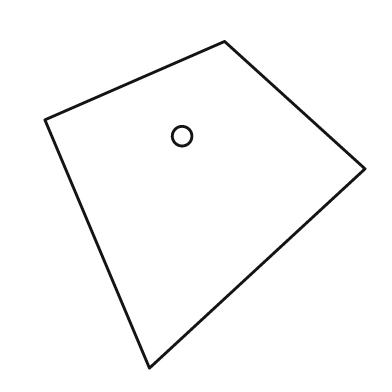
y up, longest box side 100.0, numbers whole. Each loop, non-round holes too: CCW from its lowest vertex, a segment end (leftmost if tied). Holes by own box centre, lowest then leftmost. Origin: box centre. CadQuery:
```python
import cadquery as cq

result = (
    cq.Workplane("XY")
    .moveTo(-17.0, -50.0)
    .lineTo(49.0, 11.0)
    .lineTo(6.0, 50.0)
    .lineTo(-49.0, 26.0)
    .close()
    .moveTo(-7.0, 21.0)
    .circle(3.0)
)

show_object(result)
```